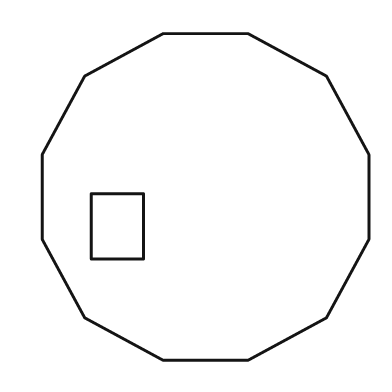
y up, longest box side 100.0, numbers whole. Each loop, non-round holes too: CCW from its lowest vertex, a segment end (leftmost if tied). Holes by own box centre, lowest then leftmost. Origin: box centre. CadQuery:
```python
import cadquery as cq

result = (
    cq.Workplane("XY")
    .moveTo(-13.0, -50.0)
    .lineTo(13.0, -50.0)
    .lineTo(37.0, -37.0)
    .lineTo(50.0, -13.0)
    .lineTo(50.0, 13.0)
    .lineTo(37.0, 37.0)
    .lineTo(13.0, 50.0)
    .lineTo(-13.0, 50.0)
    .lineTo(-37.0, 37.0)
    .lineTo(-50.0, 13.0)
    .lineTo(-50.0, -13.0)
    .lineTo(-37.0, -37.0)
    .close()
    .moveTo(-35.0, -19.0)
    .lineTo(-19.0, -19.0)
    .lineTo(-19.0, 1.0)
    .lineTo(-35.0, 1.0)
    .close()
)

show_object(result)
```